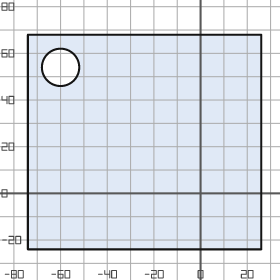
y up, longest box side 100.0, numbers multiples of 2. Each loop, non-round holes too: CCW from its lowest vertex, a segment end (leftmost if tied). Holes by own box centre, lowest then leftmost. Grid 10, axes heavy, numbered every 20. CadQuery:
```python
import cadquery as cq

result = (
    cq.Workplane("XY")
    .moveTo(-74.0, -24.0)
    .lineTo(26.0, -24.0)
    .lineTo(26.0, 68.0)
    .lineTo(-74.0, 68.0)
    .close()
    .moveTo(-60.0, 54.0)
    .circle(8.0)
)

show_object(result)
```